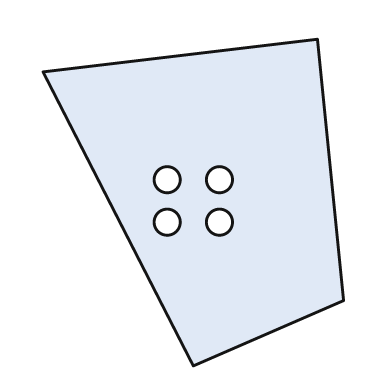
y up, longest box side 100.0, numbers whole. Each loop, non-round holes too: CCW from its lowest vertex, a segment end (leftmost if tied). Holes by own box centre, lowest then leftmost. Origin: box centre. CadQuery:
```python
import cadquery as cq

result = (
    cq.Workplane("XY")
    .moveTo(0.0, -50.0)
    .lineTo(46.0, -30.0)
    .lineTo(38.0, 50.0)
    .lineTo(-46.0, 40.0)
    .close()
    .moveTo(-8.0, -6.0)
    .circle(4.0)
    .moveTo(8.0, -6.0)
    .circle(4.0)
    .moveTo(-8.0, 7.0)
    .circle(4.0)
    .moveTo(8.0, 7.0)
    .circle(4.0)
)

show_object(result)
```